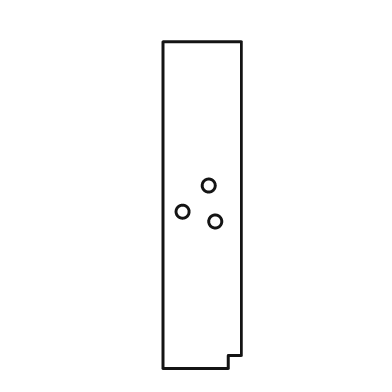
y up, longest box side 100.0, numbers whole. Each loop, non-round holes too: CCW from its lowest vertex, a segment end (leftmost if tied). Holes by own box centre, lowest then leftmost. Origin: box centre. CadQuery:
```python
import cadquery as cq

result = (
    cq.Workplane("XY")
    .moveTo(-12.0, -50.0)
    .lineTo(8.0, -50.0)
    .lineTo(8.0, -46.0)
    .lineTo(12.0, -46.0)
    .lineTo(12.0, 50.0)
    .lineTo(-12.0, 50.0)
    .close()
    .moveTo(4.0, -5.0)
    .circle(2.0)
    .moveTo(-6.0, -2.0)
    .circle(2.0)
    .moveTo(2.0, 6.0)
    .circle(2.0)
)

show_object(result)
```